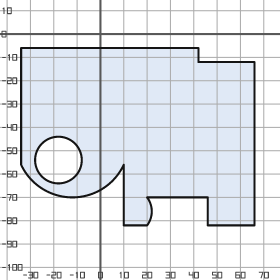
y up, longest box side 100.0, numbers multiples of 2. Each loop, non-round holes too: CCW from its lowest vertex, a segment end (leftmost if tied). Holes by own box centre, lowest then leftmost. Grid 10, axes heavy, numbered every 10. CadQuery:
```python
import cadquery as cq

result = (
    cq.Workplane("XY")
    .moveTo(10.0, -82.0)
    .lineTo(20.0, -82.0)
    .threePointArc((22.0, -76.0), (20.0, -70.0))
    .lineTo(46.0, -70.0)
    .lineTo(46.0, -82.0)
    .lineTo(66.0, -82.0)
    .lineTo(66.0, -12.0)
    .lineTo(42.0, -12.0)
    .lineTo(42.0, -6.0)
    .lineTo(-34.0, -6.0)
    .lineTo(-34.0, -56.0)
    .threePointArc((-12.0, -70.0), (10.0, -56.0))
    .close()
    .moveTo(-18.0, -54.0)
    .circle(10.0)
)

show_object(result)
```